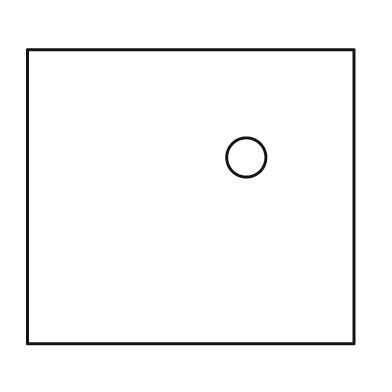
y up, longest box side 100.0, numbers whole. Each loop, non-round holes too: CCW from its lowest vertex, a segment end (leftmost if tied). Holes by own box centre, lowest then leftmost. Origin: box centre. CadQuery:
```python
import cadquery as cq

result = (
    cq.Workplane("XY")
    .moveTo(-50.0, -45.0)
    .lineTo(50.0, -45.0)
    .lineTo(50.0, 45.0)
    .lineTo(-50.0, 45.0)
    .close()
    .moveTo(17.0, 12.0)
    .circle(6.0)
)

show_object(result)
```